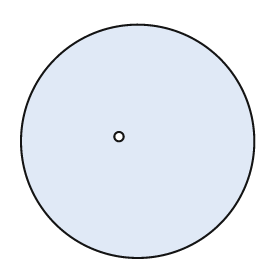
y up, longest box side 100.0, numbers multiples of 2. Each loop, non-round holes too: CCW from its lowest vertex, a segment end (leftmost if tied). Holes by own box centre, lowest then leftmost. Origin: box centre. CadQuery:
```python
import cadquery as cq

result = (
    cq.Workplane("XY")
    .moveTo(0.0, 0.0)
    .circle(50.0)
    .moveTo(-8.0, 2.0)
    .circle(2.0)
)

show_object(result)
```